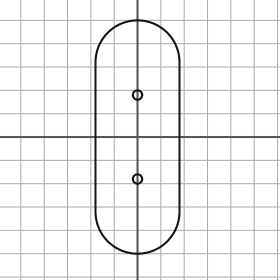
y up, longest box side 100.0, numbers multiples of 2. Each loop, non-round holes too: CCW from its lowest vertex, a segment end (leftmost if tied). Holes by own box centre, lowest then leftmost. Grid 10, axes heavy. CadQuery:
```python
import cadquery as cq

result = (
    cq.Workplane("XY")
    .moveTo(-18.0, -32.0)
    .threePointArc((0.0, -50.0), (18.0, -32.0))
    .lineTo(18.0, 32.0)
    .threePointArc((0.0, 50.0), (-18.0, 32.0))
    .close()
    .moveTo(0.0, -18.0)
    .circle(2.0)
    .moveTo(0.0, 18.0)
    .circle(2.0)
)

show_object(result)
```